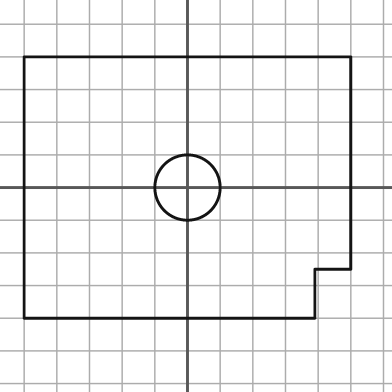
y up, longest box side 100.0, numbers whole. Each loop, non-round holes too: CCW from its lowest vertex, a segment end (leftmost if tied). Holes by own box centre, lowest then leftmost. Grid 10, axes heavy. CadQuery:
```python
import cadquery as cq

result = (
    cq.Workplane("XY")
    .moveTo(-50.0, -40.0)
    .lineTo(39.0, -40.0)
    .lineTo(39.0, -25.0)
    .lineTo(50.0, -25.0)
    .lineTo(50.0, 40.0)
    .lineTo(-50.0, 40.0)
    .close()
    .moveTo(0.0, 0.0)
    .circle(10.0)
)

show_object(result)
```